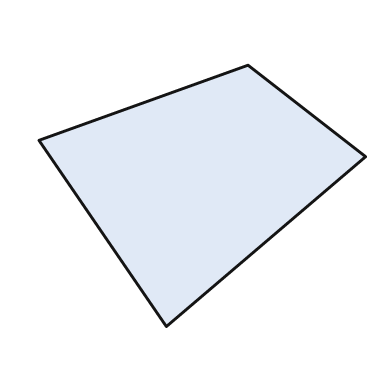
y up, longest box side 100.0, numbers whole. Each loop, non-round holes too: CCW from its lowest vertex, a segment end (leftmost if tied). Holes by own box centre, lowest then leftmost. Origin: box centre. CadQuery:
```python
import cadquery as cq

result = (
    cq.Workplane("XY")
    .moveTo(-11.0, -40.0)
    .lineTo(50.0, 12.0)
    .lineTo(14.0, 40.0)
    .lineTo(-50.0, 17.0)
    .close()
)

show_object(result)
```